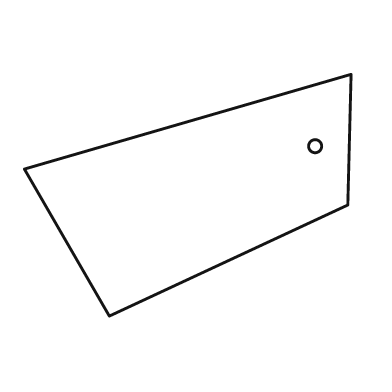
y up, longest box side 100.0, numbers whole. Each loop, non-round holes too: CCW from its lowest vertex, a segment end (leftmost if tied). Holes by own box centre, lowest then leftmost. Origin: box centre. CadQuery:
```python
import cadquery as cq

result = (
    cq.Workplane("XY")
    .moveTo(-24.0, -37.0)
    .lineTo(49.0, -3.0)
    .lineTo(50.0, 37.0)
    .lineTo(-50.0, 8.0)
    .close()
    .moveTo(39.0, 15.0)
    .circle(2.0)
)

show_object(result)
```